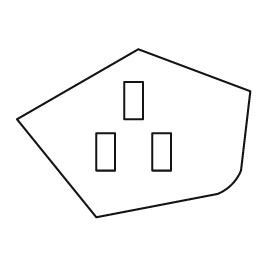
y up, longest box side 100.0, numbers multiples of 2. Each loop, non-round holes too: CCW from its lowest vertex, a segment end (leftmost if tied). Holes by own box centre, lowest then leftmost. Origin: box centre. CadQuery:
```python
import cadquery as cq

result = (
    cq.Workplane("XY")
    .moveTo(-16.0, -36.0)
    .lineTo(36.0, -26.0)
    .threePointArc((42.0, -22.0), (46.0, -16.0))
    .lineTo(50.0, 18.0)
    .lineTo(2.0, 36.0)
    .lineTo(-50.0, 6.0)
    .close()
    .moveTo(-16.0, -16.0)
    .lineTo(-8.0, -16.0)
    .lineTo(-8.0, 0.0)
    .lineTo(-16.0, 0.0)
    .close()
    .moveTo(8.0, -16.0)
    .lineTo(16.0, -16.0)
    .lineTo(16.0, 0.0)
    .lineTo(8.0, 0.0)
    .close()
    .moveTo(-4.0, 6.0)
    .lineTo(4.0, 6.0)
    .lineTo(4.0, 22.0)
    .lineTo(-4.0, 22.0)
    .close()
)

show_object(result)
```